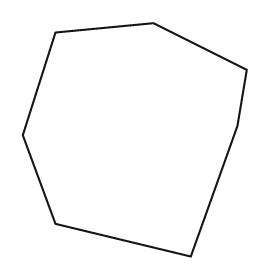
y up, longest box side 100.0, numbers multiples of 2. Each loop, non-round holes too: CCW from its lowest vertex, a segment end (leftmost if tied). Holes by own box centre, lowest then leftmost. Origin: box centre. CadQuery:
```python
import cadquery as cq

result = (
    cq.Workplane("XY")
    .moveTo(24.0, -50.0)
    .lineTo(44.0, 6.0)
    .lineTo(48.0, 30.0)
    .lineTo(8.0, 50.0)
    .lineTo(-34.0, 46.0)
    .lineTo(-48.0, 2.0)
    .lineTo(-34.0, -36.0)
    .close()
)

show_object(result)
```